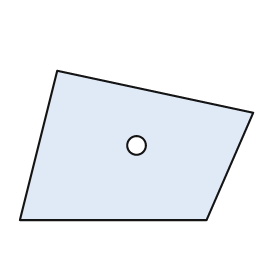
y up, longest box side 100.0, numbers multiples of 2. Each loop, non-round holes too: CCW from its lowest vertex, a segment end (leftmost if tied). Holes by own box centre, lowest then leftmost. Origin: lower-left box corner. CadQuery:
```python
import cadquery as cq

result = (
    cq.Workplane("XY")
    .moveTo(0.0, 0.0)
    .lineTo(80.0, 0.0)
    .lineTo(100.0, 46.0)
    .lineTo(16.0, 64.0)
    .close()
    .moveTo(50.0, 32.0)
    .circle(4.0)
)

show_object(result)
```